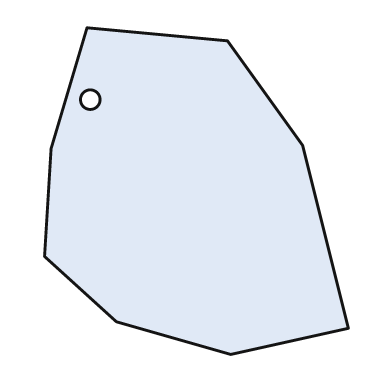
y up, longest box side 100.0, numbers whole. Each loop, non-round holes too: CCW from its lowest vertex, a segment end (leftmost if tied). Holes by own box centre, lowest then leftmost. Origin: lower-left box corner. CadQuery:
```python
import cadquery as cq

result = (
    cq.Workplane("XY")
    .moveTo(57.0, 0.0)
    .lineTo(93.0, 8.0)
    .lineTo(79.0, 64.0)
    .lineTo(56.0, 96.0)
    .lineTo(13.0, 100.0)
    .lineTo(2.0, 63.0)
    .lineTo(0.0, 30.0)
    .lineTo(22.0, 10.0)
    .close()
    .moveTo(14.0, 78.0)
    .circle(3.0)
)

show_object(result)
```